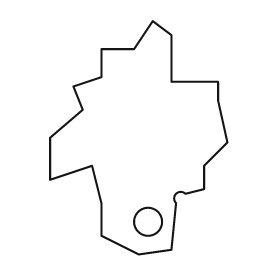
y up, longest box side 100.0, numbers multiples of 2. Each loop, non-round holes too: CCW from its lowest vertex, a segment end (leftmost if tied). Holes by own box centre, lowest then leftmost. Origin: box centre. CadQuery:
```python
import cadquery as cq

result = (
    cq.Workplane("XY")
    .moveTo(0.0, -50.0)
    .lineTo(14.0, -48.0)
    .lineTo(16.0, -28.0)
    .threePointArc((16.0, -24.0), (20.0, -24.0))
    .lineTo(28.0, -22.0)
    .lineTo(28.0, -12.0)
    .lineTo(38.0, -2.0)
    .lineTo(34.0, 16.0)
    .lineTo(34.0, 24.0)
    .lineTo(14.0, 24.0)
    .lineTo(14.0, 44.0)
    .lineTo(6.0, 50.0)
    .lineTo(-2.0, 38.0)
    .lineTo(-16.0, 38.0)
    .lineTo(-16.0, 26.0)
    .lineTo(-28.0, 22.0)
    .lineTo(-24.0, 12.0)
    .lineTo(-38.0, 0.0)
    .lineTo(-38.0, -18.0)
    .lineTo(-20.0, -12.0)
    .lineTo(-16.0, -28.0)
    .lineTo(-16.0, -42.0)
    .close()
    .moveTo(4.0, -36.0)
    .circle(6.0)
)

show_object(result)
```